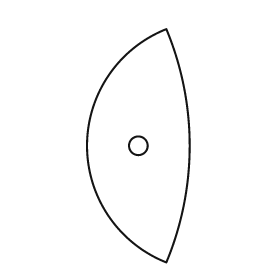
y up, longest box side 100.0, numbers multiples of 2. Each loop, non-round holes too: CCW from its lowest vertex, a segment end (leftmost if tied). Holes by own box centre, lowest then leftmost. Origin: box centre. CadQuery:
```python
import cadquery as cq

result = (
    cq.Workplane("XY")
    .moveTo(12.0, -50.0)
    .threePointArc((22.0, 0.0), (12.0, 50.0))
    .threePointArc((-22.0, 0.0), (12.0, -50.0))
    .close()
    .moveTo(0.0, 0.0)
    .circle(4.0)
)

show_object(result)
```